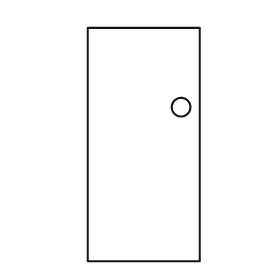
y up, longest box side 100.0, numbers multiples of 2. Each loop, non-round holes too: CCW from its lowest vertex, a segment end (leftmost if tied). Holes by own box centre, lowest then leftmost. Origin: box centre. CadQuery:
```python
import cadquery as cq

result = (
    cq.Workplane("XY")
    .moveTo(-24.0, -50.0)
    .lineTo(24.0, -50.0)
    .lineTo(24.0, 50.0)
    .lineTo(-24.0, 50.0)
    .close()
    .moveTo(16.0, 16.0)
    .circle(4.0)
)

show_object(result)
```